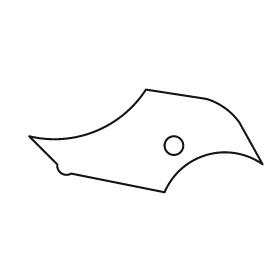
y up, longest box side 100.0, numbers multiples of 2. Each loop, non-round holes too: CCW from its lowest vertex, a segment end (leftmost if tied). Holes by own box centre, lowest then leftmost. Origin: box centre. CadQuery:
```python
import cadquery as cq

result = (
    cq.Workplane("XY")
    .moveTo(8.0, -22.0)
    .threePointArc((26.0, -6.0), (50.0, -10.0))
    .lineTo(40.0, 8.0)
    .threePointArc((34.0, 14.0), (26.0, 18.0))
    .lineTo(0.0, 22.0)
    .threePointArc((-22.0, 4.0), (-50.0, 2.0))
    .lineTo(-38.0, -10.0)
    .threePointArc((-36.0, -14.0), (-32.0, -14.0))
    .close()
    .moveTo(12.0, -2.0)
    .circle(4.0)
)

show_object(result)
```